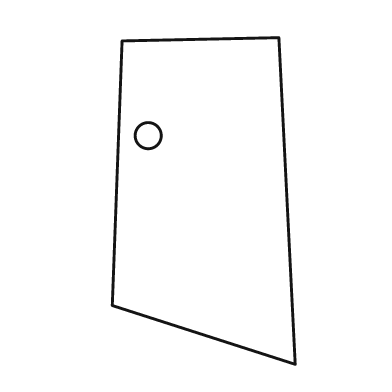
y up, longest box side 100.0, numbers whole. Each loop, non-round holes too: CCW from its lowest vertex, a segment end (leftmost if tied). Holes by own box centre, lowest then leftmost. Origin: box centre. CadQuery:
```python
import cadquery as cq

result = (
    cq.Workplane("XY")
    .moveTo(28.0, -50.0)
    .lineTo(23.0, 50.0)
    .lineTo(-25.0, 49.0)
    .lineTo(-28.0, -32.0)
    .close()
    .moveTo(-17.0, 20.0)
    .circle(4.0)
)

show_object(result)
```